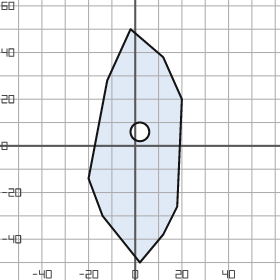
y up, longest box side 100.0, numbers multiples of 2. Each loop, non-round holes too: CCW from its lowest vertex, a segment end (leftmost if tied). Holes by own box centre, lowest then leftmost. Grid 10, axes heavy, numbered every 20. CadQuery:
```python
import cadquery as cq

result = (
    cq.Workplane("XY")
    .moveTo(2.0, -50.0)
    .lineTo(12.0, -38.0)
    .lineTo(18.0, -26.0)
    .lineTo(20.0, 20.0)
    .lineTo(12.0, 38.0)
    .lineTo(-2.0, 50.0)
    .lineTo(-12.0, 28.0)
    .lineTo(-20.0, -14.0)
    .lineTo(-14.0, -30.0)
    .close()
    .moveTo(2.0, 6.0)
    .circle(4.0)
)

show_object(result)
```